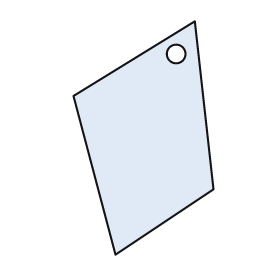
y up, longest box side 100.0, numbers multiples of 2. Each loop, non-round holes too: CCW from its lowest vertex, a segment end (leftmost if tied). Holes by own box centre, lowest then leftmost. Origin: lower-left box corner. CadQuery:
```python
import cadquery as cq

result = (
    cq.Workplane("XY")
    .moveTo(18.0, 0.0)
    .lineTo(60.0, 28.0)
    .lineTo(52.0, 100.0)
    .lineTo(0.0, 68.0)
    .close()
    .moveTo(44.0, 86.0)
    .circle(4.0)
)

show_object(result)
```